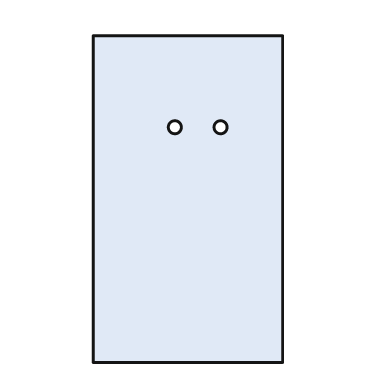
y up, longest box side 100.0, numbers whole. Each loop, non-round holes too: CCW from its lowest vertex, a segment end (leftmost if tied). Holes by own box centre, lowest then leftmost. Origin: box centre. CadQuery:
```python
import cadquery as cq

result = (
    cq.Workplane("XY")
    .moveTo(-29.0, -50.0)
    .lineTo(29.0, -50.0)
    .lineTo(29.0, 50.0)
    .lineTo(-29.0, 50.0)
    .close()
    .moveTo(-4.0, 22.0)
    .circle(2.0)
    .moveTo(10.0, 22.0)
    .circle(2.0)
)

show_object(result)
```